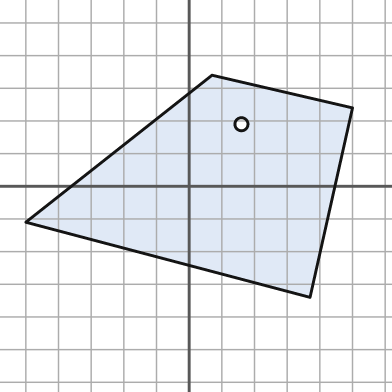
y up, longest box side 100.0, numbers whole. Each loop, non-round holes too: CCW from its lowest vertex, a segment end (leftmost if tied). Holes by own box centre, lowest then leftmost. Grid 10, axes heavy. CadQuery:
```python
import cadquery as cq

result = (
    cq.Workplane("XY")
    .moveTo(37.0, -34.0)
    .lineTo(50.0, 24.0)
    .lineTo(7.0, 34.0)
    .lineTo(-50.0, -11.0)
    .close()
    .moveTo(16.0, 19.0)
    .circle(2.0)
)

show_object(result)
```